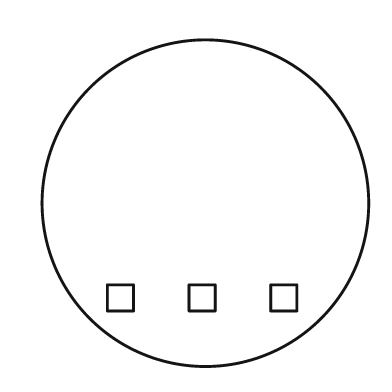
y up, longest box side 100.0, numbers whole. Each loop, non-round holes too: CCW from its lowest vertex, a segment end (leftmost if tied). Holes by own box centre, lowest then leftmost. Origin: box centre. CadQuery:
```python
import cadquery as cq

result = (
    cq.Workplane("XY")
    .moveTo(0.0, 0.0)
    .circle(50.0)
    .moveTo(-30.0, -33.0)
    .lineTo(-22.0, -33.0)
    .lineTo(-22.0, -25.0)
    .lineTo(-30.0, -25.0)
    .close()
    .moveTo(-5.0, -33.0)
    .lineTo(3.0, -33.0)
    .lineTo(3.0, -25.0)
    .lineTo(-5.0, -25.0)
    .close()
    .moveTo(20.0, -33.0)
    .lineTo(28.0, -33.0)
    .lineTo(28.0, -25.0)
    .lineTo(20.0, -25.0)
    .close()
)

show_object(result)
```